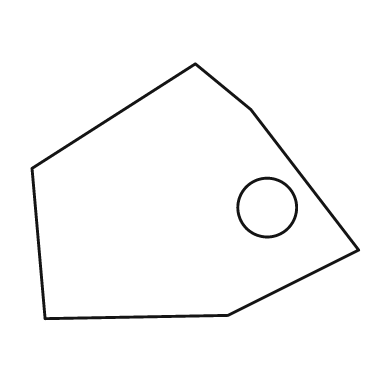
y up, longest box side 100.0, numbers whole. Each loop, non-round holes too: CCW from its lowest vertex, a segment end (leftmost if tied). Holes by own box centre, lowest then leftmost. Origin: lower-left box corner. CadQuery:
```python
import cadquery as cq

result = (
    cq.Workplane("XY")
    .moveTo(4.0, 0.0)
    .lineTo(60.0, 1.0)
    .lineTo(100.0, 21.0)
    .lineTo(67.0, 64.0)
    .lineTo(50.0, 78.0)
    .lineTo(0.0, 46.0)
    .close()
    .moveTo(72.0, 34.0)
    .circle(9.0)
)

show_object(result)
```